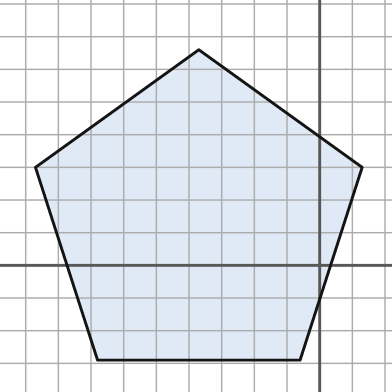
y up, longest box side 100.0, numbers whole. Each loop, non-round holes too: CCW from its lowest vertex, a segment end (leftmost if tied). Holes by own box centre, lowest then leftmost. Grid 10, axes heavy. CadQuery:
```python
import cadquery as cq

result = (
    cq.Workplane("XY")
    .moveTo(-68.0, -29.0)
    .lineTo(-6.0, -29.0)
    .lineTo(13.0, 30.0)
    .lineTo(-37.0, 66.0)
    .lineTo(-87.0, 30.0)
    .close()
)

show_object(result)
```